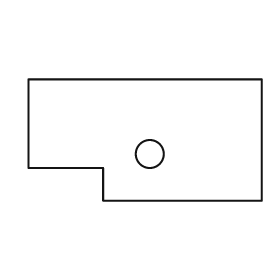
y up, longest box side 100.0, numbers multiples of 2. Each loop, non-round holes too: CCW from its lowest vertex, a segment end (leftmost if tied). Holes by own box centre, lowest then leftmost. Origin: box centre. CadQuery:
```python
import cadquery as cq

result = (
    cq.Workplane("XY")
    .moveTo(-18.0, -26.0)
    .lineTo(50.0, -26.0)
    .lineTo(50.0, 26.0)
    .lineTo(-50.0, 26.0)
    .lineTo(-50.0, -12.0)
    .lineTo(-18.0, -12.0)
    .close()
    .moveTo(2.0, -6.0)
    .circle(6.0)
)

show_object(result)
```